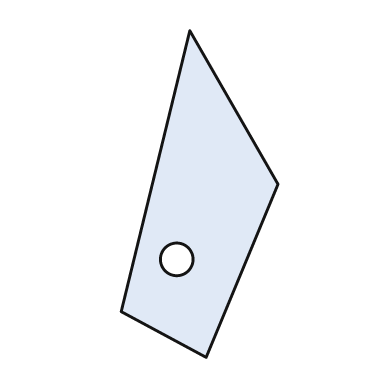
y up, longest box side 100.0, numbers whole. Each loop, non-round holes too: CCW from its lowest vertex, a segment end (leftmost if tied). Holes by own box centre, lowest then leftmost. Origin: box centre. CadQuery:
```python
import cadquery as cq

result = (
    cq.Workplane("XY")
    .moveTo(2.0, -50.0)
    .lineTo(24.0, 3.0)
    .lineTo(-3.0, 50.0)
    .lineTo(-24.0, -36.0)
    .close()
    .moveTo(-7.0, -20.0)
    .circle(5.0)
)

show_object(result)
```